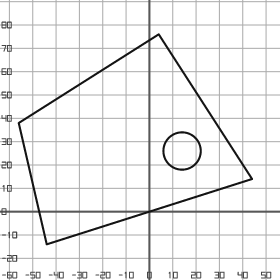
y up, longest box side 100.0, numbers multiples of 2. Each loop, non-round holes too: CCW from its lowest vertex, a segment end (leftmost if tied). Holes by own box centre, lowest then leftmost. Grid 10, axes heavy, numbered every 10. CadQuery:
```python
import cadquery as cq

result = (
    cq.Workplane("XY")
    .moveTo(-44.0, -14.0)
    .lineTo(44.0, 14.0)
    .lineTo(4.0, 76.0)
    .lineTo(-56.0, 38.0)
    .close()
    .moveTo(14.0, 26.0)
    .circle(8.0)
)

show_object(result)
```